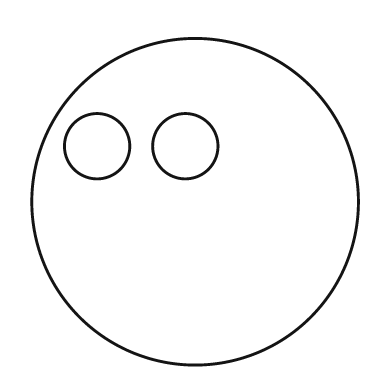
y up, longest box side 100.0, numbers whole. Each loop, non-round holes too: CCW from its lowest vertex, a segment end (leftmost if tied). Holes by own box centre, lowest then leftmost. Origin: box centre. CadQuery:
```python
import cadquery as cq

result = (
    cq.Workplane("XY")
    .moveTo(0.0, 0.0)
    .circle(50.0)
    .moveTo(-30.0, 17.0)
    .circle(10.0)
    .moveTo(-3.0, 17.0)
    .circle(10.0)
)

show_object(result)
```